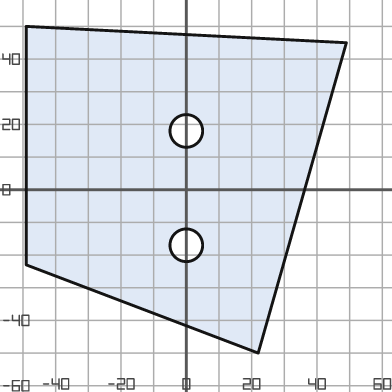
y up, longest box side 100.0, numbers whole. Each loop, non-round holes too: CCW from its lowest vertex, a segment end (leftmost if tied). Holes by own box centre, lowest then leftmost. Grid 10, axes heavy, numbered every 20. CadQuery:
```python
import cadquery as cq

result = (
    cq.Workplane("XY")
    .moveTo(22.0, -50.0)
    .lineTo(49.0, 45.0)
    .lineTo(-49.0, 50.0)
    .lineTo(-49.0, -23.0)
    .close()
    .moveTo(0.0, -17.0)
    .circle(5.0)
    .moveTo(0.0, 18.0)
    .circle(5.0)
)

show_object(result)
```